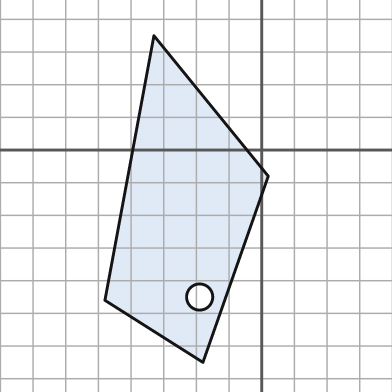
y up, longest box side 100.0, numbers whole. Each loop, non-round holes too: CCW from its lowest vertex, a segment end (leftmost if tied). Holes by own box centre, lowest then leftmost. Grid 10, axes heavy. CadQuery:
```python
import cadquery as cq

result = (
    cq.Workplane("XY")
    .moveTo(-18.0, -65.0)
    .lineTo(2.0, -8.0)
    .lineTo(-33.0, 35.0)
    .lineTo(-48.0, -46.0)
    .close()
    .moveTo(-19.0, -45.0)
    .circle(4.0)
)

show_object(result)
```